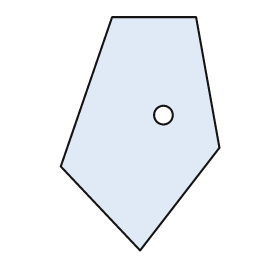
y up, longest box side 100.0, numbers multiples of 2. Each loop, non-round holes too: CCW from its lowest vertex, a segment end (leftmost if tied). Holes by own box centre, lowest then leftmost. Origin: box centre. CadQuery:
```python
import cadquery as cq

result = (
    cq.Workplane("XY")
    .moveTo(0.0, -50.0)
    .lineTo(34.0, -6.0)
    .lineTo(24.0, 50.0)
    .lineTo(-12.0, 50.0)
    .lineTo(-34.0, -14.0)
    .close()
    .moveTo(10.0, 8.0)
    .circle(4.0)
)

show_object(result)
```